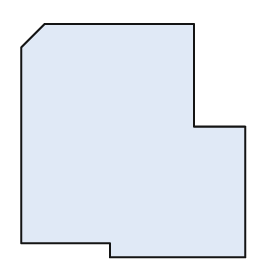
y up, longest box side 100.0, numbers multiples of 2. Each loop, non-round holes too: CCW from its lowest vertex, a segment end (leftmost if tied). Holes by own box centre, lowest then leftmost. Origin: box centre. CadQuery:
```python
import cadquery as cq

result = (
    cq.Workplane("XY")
    .moveTo(-10.0, -50.0)
    .lineTo(48.0, -50.0)
    .lineTo(48.0, 6.0)
    .lineTo(26.0, 6.0)
    .lineTo(26.0, 50.0)
    .lineTo(-38.0, 50.0)
    .lineTo(-48.0, 40.0)
    .lineTo(-48.0, -44.0)
    .lineTo(-10.0, -44.0)
    .close()
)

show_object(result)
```